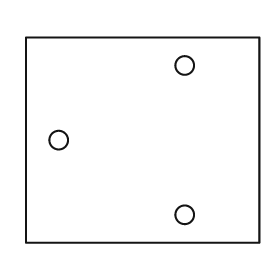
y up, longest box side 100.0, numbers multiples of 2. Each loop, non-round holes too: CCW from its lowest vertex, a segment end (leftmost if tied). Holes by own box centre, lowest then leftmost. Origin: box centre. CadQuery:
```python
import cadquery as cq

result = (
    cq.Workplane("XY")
    .moveTo(-50.0, -44.0)
    .lineTo(50.0, -44.0)
    .lineTo(50.0, 44.0)
    .lineTo(-50.0, 44.0)
    .close()
    .moveTo(18.0, -32.0)
    .circle(4.0)
    .moveTo(-36.0, 0.0)
    .circle(4.0)
    .moveTo(18.0, 32.0)
    .circle(4.0)
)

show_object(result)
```